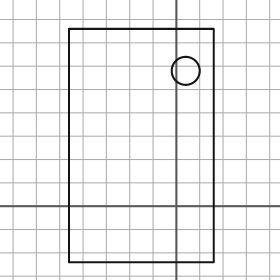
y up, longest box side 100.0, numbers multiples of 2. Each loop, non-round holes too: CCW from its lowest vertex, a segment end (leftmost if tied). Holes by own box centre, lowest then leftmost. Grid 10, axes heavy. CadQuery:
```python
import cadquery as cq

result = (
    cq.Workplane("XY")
    .moveTo(-46.0, -24.0)
    .lineTo(16.0, -24.0)
    .lineTo(16.0, 76.0)
    .lineTo(-46.0, 76.0)
    .close()
    .moveTo(4.0, 58.0)
    .circle(6.0)
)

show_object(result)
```